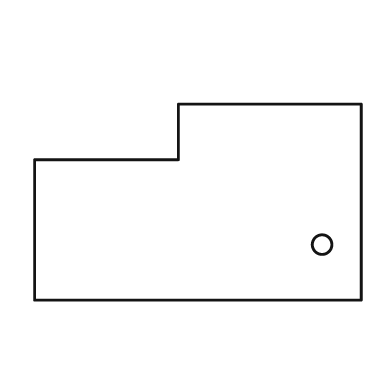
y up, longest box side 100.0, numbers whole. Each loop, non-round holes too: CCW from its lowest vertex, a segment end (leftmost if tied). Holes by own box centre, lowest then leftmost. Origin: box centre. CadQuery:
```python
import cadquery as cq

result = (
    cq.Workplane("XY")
    .moveTo(-50.0, -30.0)
    .lineTo(50.0, -30.0)
    .lineTo(50.0, 30.0)
    .lineTo(-6.0, 30.0)
    .lineTo(-6.0, 13.0)
    .lineTo(-50.0, 13.0)
    .close()
    .moveTo(38.0, -13.0)
    .circle(3.0)
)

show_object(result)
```